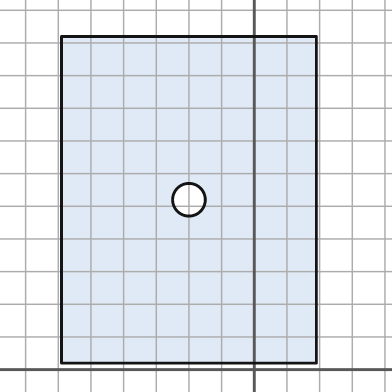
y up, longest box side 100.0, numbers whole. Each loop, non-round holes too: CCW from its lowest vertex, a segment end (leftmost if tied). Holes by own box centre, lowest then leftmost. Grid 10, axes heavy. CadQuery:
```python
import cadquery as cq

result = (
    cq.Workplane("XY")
    .moveTo(-59.0, 2.0)
    .lineTo(19.0, 2.0)
    .lineTo(19.0, 102.0)
    .lineTo(-59.0, 102.0)
    .close()
    .moveTo(-20.0, 52.0)
    .circle(5.0)
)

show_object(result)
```